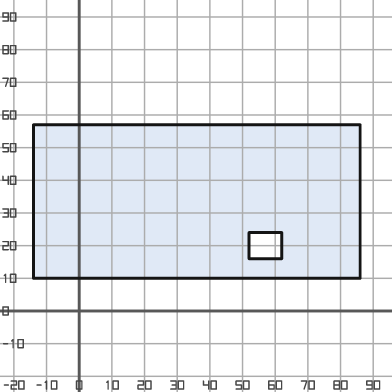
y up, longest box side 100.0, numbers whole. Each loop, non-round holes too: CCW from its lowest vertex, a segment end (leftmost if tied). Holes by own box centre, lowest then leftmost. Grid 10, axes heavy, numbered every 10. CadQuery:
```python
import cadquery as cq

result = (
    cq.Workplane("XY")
    .moveTo(-14.0, 10.0)
    .lineTo(86.0, 10.0)
    .lineTo(86.0, 57.0)
    .lineTo(-14.0, 57.0)
    .close()
    .moveTo(52.0, 16.0)
    .lineTo(62.0, 16.0)
    .lineTo(62.0, 24.0)
    .lineTo(52.0, 24.0)
    .close()
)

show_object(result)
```